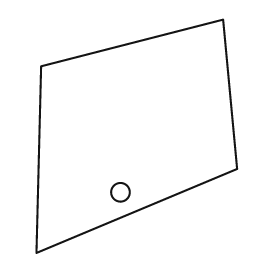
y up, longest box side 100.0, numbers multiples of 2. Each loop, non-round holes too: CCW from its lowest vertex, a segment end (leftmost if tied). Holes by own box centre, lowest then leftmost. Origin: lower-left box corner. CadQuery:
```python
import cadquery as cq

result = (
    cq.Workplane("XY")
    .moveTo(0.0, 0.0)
    .lineTo(86.0, 36.0)
    .lineTo(80.0, 100.0)
    .lineTo(2.0, 80.0)
    .close()
    .moveTo(36.0, 26.0)
    .circle(4.0)
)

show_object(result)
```